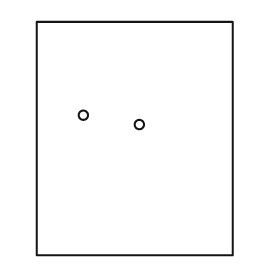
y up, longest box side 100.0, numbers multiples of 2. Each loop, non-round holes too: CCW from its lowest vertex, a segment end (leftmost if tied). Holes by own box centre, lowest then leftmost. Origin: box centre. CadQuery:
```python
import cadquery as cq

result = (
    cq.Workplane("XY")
    .moveTo(-42.0, -50.0)
    .lineTo(42.0, -50.0)
    .lineTo(42.0, 50.0)
    .lineTo(-42.0, 50.0)
    .close()
    .moveTo(2.0, 6.0)
    .circle(2.0)
    .moveTo(-22.0, 10.0)
    .circle(2.0)
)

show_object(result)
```